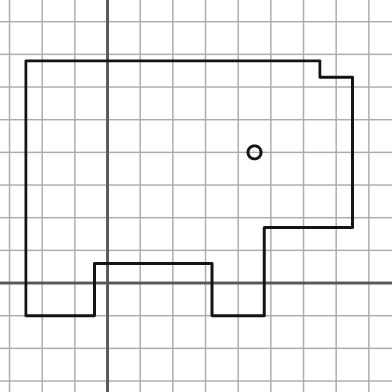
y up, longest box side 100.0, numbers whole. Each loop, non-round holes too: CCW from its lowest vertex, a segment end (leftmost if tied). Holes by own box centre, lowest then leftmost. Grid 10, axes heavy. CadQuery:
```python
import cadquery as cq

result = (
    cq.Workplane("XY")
    .moveTo(-25.0, -10.0)
    .lineTo(-4.0, -10.0)
    .lineTo(-4.0, 6.0)
    .lineTo(32.0, 6.0)
    .lineTo(32.0, -10.0)
    .lineTo(48.0, -10.0)
    .lineTo(48.0, 17.0)
    .lineTo(75.0, 17.0)
    .lineTo(75.0, 63.0)
    .lineTo(65.0, 63.0)
    .lineTo(65.0, 68.0)
    .lineTo(-25.0, 68.0)
    .close()
    .moveTo(45.0, 40.0)
    .circle(2.0)
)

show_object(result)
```